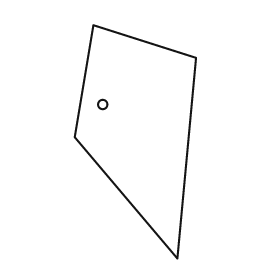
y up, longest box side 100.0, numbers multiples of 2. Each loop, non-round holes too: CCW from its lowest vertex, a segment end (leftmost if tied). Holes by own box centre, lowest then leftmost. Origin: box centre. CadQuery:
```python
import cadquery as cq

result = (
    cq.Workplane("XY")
    .moveTo(18.0, -50.0)
    .lineTo(26.0, 36.0)
    .lineTo(-18.0, 50.0)
    .lineTo(-26.0, 2.0)
    .close()
    .moveTo(-14.0, 16.0)
    .circle(2.0)
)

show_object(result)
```